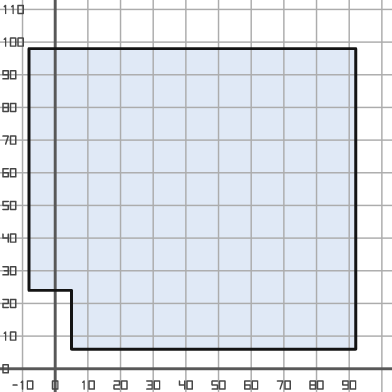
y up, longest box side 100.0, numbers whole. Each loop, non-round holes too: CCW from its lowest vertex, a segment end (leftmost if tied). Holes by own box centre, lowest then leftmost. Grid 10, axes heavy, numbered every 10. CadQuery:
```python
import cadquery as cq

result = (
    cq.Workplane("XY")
    .moveTo(5.0, 6.0)
    .lineTo(92.0, 6.0)
    .lineTo(92.0, 98.0)
    .lineTo(-8.0, 98.0)
    .lineTo(-8.0, 24.0)
    .lineTo(5.0, 24.0)
    .close()
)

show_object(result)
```